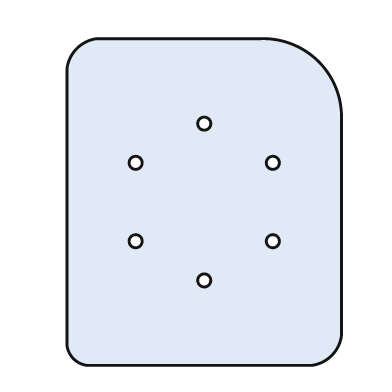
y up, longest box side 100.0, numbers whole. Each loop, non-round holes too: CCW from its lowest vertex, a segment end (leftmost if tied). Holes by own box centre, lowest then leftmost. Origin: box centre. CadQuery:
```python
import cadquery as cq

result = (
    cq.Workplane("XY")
    .moveTo(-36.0, -50.0)
    .lineTo(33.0, -50.0)
    .threePointArc((39.0, -47.0), (42.0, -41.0))
    .lineTo(42.0, 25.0)
    .threePointArc((35.0, 43.0), (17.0, 50.0))
    .lineTo(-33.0, 50.0)
    .threePointArc((-39.0, 47.0), (-42.0, 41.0))
    .lineTo(-42.0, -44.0)
    .threePointArc((-40.0, -48.0), (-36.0, -50.0))
    .close()
    .moveTo(0.0, -24.0)
    .circle(2.0)
    .moveTo(-21.0, -12.0)
    .circle(2.0)
    .moveTo(21.0, -12.0)
    .circle(2.0)
    .moveTo(-21.0, 12.0)
    .circle(2.0)
    .moveTo(21.0, 12.0)
    .circle(2.0)
    .moveTo(0.0, 24.0)
    .circle(2.0)
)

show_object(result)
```